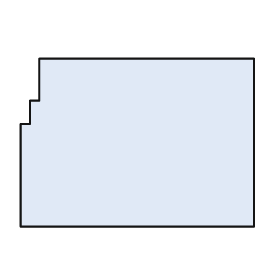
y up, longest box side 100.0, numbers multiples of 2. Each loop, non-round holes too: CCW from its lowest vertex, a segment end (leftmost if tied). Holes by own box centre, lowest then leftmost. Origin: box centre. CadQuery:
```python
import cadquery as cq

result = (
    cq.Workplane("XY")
    .moveTo(-50.0, -36.0)
    .lineTo(50.0, -36.0)
    .lineTo(50.0, 36.0)
    .lineTo(-42.0, 36.0)
    .lineTo(-42.0, 18.0)
    .lineTo(-46.0, 18.0)
    .lineTo(-46.0, 8.0)
    .lineTo(-50.0, 8.0)
    .close()
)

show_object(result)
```